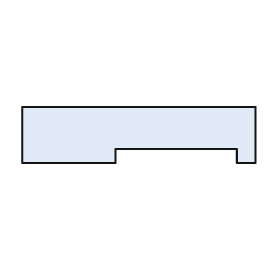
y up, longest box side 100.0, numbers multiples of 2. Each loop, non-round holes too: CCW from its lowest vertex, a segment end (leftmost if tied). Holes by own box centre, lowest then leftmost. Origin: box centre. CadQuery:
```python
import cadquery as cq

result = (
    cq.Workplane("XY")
    .moveTo(-50.0, -12.0)
    .lineTo(-10.0, -12.0)
    .lineTo(-10.0, -6.0)
    .lineTo(42.0, -6.0)
    .lineTo(42.0, -12.0)
    .lineTo(50.0, -12.0)
    .lineTo(50.0, 12.0)
    .lineTo(-50.0, 12.0)
    .close()
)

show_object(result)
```